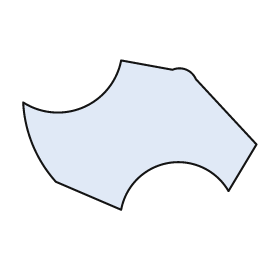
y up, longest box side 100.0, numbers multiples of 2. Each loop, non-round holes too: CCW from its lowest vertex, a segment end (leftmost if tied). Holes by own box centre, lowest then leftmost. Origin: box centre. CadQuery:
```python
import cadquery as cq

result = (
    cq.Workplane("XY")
    .moveTo(-8.0, -32.0)
    .threePointArc((12.0, -12.0), (38.0, -24.0))
    .lineTo(50.0, -4.0)
    .lineTo(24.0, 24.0)
    .threePointArc((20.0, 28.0), (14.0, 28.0))
    .lineTo(-8.0, 32.0)
    .threePointArc((-24.0, 12.0), (-50.0, 14.0))
    .threePointArc((-46.0, -4.0), (-36.0, -20.0))
    .close()
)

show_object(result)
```